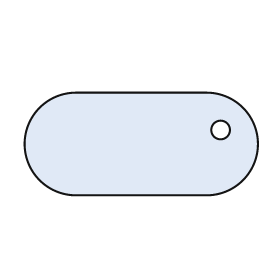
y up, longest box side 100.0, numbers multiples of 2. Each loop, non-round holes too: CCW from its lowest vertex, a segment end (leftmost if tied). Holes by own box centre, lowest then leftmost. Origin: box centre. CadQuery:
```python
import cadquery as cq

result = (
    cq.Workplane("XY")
    .moveTo(-28.0, -22.0)
    .lineTo(28.0, -22.0)
    .threePointArc((50.0, 0.0), (28.0, 22.0))
    .lineTo(-28.0, 22.0)
    .threePointArc((-50.0, 0.0), (-28.0, -22.0))
    .close()
    .moveTo(34.0, 6.0)
    .circle(4.0)
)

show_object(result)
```